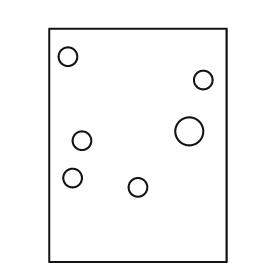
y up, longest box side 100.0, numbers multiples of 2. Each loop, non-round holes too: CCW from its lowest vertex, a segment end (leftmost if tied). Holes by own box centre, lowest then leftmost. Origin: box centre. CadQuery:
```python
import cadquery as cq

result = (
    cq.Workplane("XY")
    .moveTo(-38.0, -50.0)
    .lineTo(38.0, -50.0)
    .lineTo(38.0, 50.0)
    .lineTo(-38.0, 50.0)
    .close()
    .moveTo(0.0, -18.0)
    .circle(4.0)
    .moveTo(-28.0, -14.0)
    .circle(4.0)
    .moveTo(-24.0, 2.0)
    .circle(4.0)
    .moveTo(22.0, 6.0)
    .circle(6.0)
    .moveTo(28.0, 28.0)
    .circle(4.0)
    .moveTo(-30.0, 38.0)
    .circle(4.0)
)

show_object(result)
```